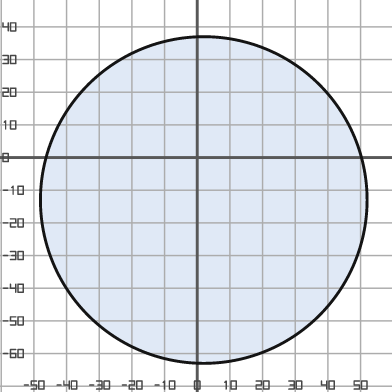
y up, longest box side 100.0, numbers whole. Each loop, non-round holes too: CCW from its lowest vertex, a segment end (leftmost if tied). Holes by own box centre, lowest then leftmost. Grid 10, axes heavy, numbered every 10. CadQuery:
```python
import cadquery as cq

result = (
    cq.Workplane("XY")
    .moveTo(2.0, -13.0)
    .circle(50.0)
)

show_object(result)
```